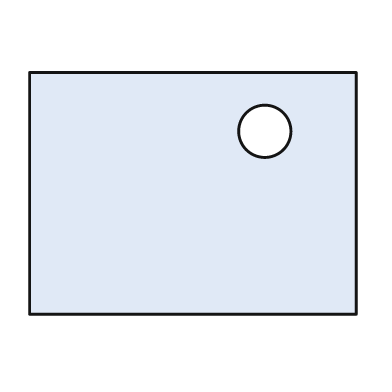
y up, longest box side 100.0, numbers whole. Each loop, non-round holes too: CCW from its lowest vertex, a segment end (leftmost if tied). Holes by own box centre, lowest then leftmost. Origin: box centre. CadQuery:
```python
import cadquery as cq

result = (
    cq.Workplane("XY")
    .moveTo(-50.0, -37.0)
    .lineTo(50.0, -37.0)
    .lineTo(50.0, 37.0)
    .lineTo(-50.0, 37.0)
    .close()
    .moveTo(22.0, 19.0)
    .circle(8.0)
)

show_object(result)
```